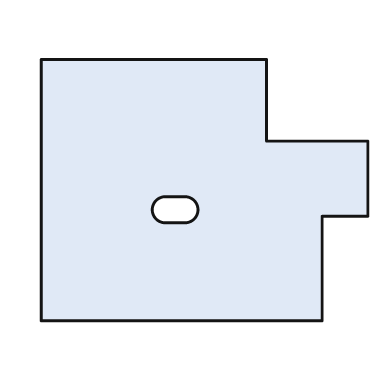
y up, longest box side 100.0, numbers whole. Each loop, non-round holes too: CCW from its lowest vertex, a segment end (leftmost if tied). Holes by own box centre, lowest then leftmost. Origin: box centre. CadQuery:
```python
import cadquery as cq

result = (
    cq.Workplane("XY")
    .moveTo(-50.0, -40.0)
    .lineTo(36.0, -40.0)
    .lineTo(36.0, -8.0)
    .lineTo(50.0, -8.0)
    .lineTo(50.0, 15.0)
    .lineTo(19.0, 15.0)
    .lineTo(19.0, 40.0)
    .lineTo(-50.0, 40.0)
    .close()
    .moveTo(-12.0, -10.0)
    .lineTo(-6.0, -10.0)
    .threePointArc((-2.0, -6.0), (-6.0, -2.0))
    .lineTo(-12.0, -2.0)
    .threePointArc((-16.0, -6.0), (-12.0, -10.0))
    .close()
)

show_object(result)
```